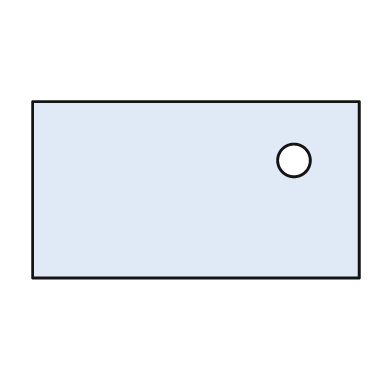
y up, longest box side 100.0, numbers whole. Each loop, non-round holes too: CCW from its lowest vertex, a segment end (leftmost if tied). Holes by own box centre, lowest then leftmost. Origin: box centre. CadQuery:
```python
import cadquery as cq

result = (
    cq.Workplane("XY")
    .moveTo(-50.0, -27.0)
    .lineTo(50.0, -27.0)
    .lineTo(50.0, 27.0)
    .lineTo(-50.0, 27.0)
    .close()
    .moveTo(30.0, 9.0)
    .circle(5.0)
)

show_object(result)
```